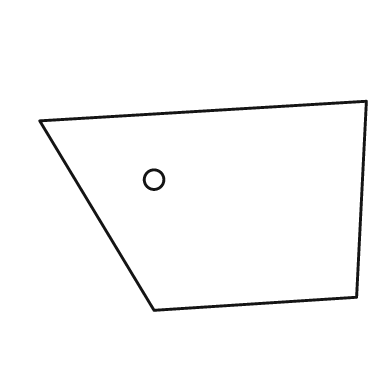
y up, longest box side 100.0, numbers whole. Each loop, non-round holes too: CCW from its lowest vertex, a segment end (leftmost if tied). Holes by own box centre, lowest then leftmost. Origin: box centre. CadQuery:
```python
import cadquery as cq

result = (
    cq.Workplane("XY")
    .moveTo(-15.0, -32.0)
    .lineTo(47.0, -28.0)
    .lineTo(50.0, 32.0)
    .lineTo(-50.0, 26.0)
    .close()
    .moveTo(-15.0, 8.0)
    .circle(3.0)
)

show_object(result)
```